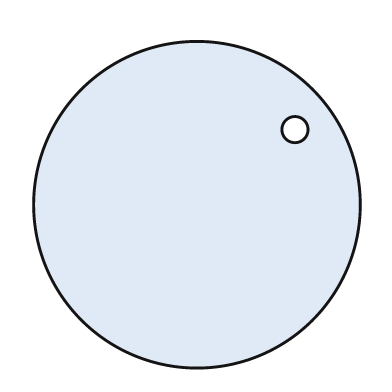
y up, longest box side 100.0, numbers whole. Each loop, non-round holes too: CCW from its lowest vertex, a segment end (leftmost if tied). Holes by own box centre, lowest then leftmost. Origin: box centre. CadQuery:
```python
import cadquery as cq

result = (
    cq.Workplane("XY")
    .moveTo(0.0, 0.0)
    .circle(50.0)
    .moveTo(30.0, 23.0)
    .circle(4.0)
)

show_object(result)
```